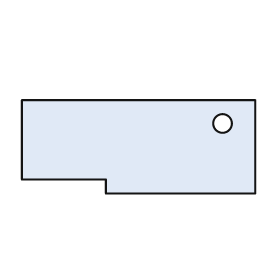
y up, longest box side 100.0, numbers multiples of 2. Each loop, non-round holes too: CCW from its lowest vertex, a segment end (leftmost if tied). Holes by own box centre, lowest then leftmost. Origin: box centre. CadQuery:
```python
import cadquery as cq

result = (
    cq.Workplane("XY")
    .moveTo(-14.0, -20.0)
    .lineTo(50.0, -20.0)
    .lineTo(50.0, 20.0)
    .lineTo(-50.0, 20.0)
    .lineTo(-50.0, -14.0)
    .lineTo(-14.0, -14.0)
    .close()
    .moveTo(36.0, 10.0)
    .circle(4.0)
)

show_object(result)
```